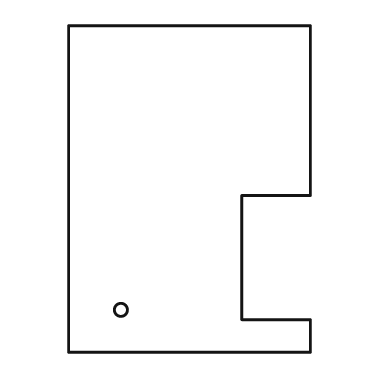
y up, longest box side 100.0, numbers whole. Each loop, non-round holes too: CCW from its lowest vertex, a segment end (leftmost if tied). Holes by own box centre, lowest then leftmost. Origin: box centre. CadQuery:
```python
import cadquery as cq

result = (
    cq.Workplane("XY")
    .moveTo(-37.0, -50.0)
    .lineTo(37.0, -50.0)
    .lineTo(37.0, -40.0)
    .lineTo(16.0, -40.0)
    .lineTo(16.0, -2.0)
    .lineTo(37.0, -2.0)
    .lineTo(37.0, 50.0)
    .lineTo(-37.0, 50.0)
    .close()
    .moveTo(-21.0, -37.0)
    .circle(2.0)
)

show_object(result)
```